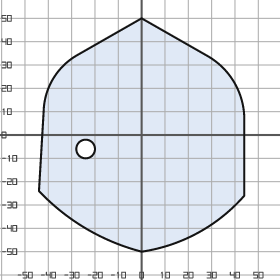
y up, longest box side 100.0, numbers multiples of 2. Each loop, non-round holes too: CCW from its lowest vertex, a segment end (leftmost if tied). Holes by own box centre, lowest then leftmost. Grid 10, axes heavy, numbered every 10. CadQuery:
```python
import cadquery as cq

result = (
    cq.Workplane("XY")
    .moveTo(0.0, -50.0)
    .threePointArc((24.0, -42.0), (44.0, -26.0))
    .lineTo(44.0, 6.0)
    .threePointArc((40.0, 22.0), (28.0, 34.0))
    .lineTo(0.0, 50.0)
    .lineTo(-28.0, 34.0)
    .threePointArc((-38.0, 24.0), (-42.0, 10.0))
    .lineTo(-44.0, -24.0)
    .threePointArc((-24.0, -40.0), (0.0, -50.0))
    .close()
    .moveTo(-24.0, -6.0)
    .circle(4.0)
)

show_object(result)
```